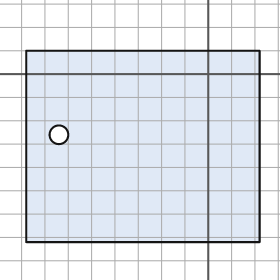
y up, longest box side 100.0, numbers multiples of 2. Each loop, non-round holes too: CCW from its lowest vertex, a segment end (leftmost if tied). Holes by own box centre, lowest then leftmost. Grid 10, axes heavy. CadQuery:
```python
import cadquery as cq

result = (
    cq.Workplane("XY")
    .moveTo(-78.0, -72.0)
    .lineTo(22.0, -72.0)
    .lineTo(22.0, 10.0)
    .lineTo(-78.0, 10.0)
    .close()
    .moveTo(-64.0, -26.0)
    .circle(4.0)
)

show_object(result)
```